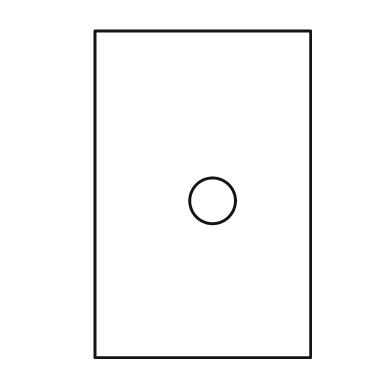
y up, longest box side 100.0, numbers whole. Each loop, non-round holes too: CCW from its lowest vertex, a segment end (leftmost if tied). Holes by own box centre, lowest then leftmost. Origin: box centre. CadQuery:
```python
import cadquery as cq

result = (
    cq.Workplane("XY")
    .moveTo(-33.0, -50.0)
    .lineTo(33.0, -50.0)
    .lineTo(33.0, 50.0)
    .lineTo(-33.0, 50.0)
    .close()
    .moveTo(3.0, -2.0)
    .circle(7.0)
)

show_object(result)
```